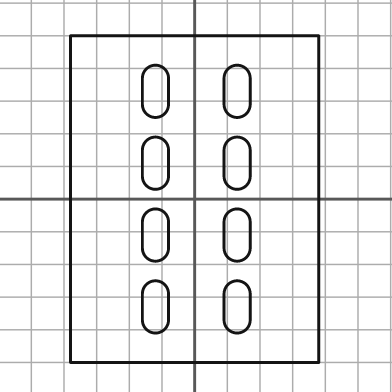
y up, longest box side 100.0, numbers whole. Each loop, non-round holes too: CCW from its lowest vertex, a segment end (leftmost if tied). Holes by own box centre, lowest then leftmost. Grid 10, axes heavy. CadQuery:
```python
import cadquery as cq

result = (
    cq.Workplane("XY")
    .moveTo(-38.0, -50.0)
    .lineTo(38.0, -50.0)
    .lineTo(38.0, 50.0)
    .lineTo(-38.0, 50.0)
    .close()
    .moveTo(-16.0, -37.0)
    .threePointArc((-12.0, -41.0), (-8.0, -37.0))
    .lineTo(-8.0, -29.0)
    .threePointArc((-12.0, -25.0), (-16.0, -29.0))
    .close()
    .moveTo(9.0, -37.0)
    .threePointArc((13.0, -41.0), (17.0, -37.0))
    .lineTo(17.0, -29.0)
    .threePointArc((13.0, -25.0), (9.0, -29.0))
    .close()
    .moveTo(-16.0, -15.0)
    .threePointArc((-12.0, -19.0), (-8.0, -15.0))
    .lineTo(-8.0, -7.0)
    .threePointArc((-12.0, -3.0), (-16.0, -7.0))
    .close()
    .moveTo(9.0, -15.0)
    .threePointArc((13.0, -19.0), (17.0, -15.0))
    .lineTo(17.0, -7.0)
    .threePointArc((13.0, -3.0), (9.0, -7.0))
    .close()
    .moveTo(-16.0, 7.0)
    .threePointArc((-12.0, 3.0), (-8.0, 7.0))
    .lineTo(-8.0, 15.0)
    .threePointArc((-12.0, 19.0), (-16.0, 15.0))
    .close()
    .moveTo(9.0, 7.0)
    .threePointArc((13.0, 3.0), (17.0, 7.0))
    .lineTo(17.0, 15.0)
    .threePointArc((13.0, 19.0), (9.0, 15.0))
    .close()
    .moveTo(-16.0, 29.0)
    .threePointArc((-12.0, 25.0), (-8.0, 29.0))
    .lineTo(-8.0, 37.0)
    .threePointArc((-12.0, 41.0), (-16.0, 37.0))
    .close()
    .moveTo(9.0, 29.0)
    .threePointArc((13.0, 25.0), (17.0, 29.0))
    .lineTo(17.0, 37.0)
    .threePointArc((13.0, 41.0), (9.0, 37.0))
    .close()
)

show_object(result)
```